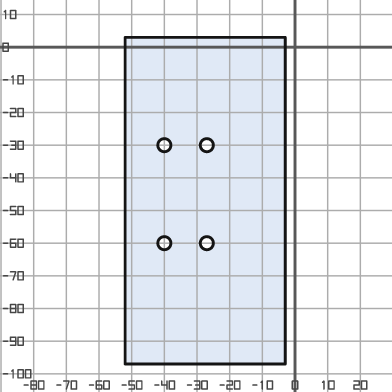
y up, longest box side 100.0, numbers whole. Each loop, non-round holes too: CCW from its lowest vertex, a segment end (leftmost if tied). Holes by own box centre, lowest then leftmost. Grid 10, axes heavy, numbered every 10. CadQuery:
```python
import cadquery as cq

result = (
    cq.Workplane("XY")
    .moveTo(-52.0, -97.0)
    .lineTo(-3.0, -97.0)
    .lineTo(-3.0, 3.0)
    .lineTo(-52.0, 3.0)
    .close()
    .moveTo(-40.0, -60.0)
    .circle(2.0)
    .moveTo(-27.0, -60.0)
    .circle(2.0)
    .moveTo(-40.0, -30.0)
    .circle(2.0)
    .moveTo(-27.0, -30.0)
    .circle(2.0)
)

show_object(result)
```